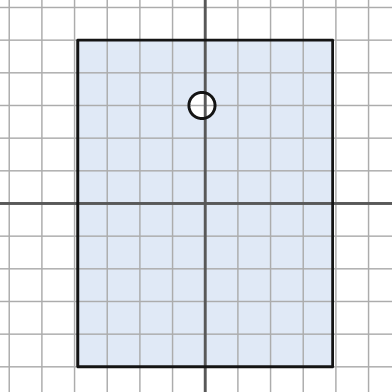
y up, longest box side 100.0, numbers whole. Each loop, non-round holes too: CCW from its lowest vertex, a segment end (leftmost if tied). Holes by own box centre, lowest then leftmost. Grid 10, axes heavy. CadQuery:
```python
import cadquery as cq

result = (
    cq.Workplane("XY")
    .moveTo(-39.0, -50.0)
    .lineTo(39.0, -50.0)
    .lineTo(39.0, 50.0)
    .lineTo(-39.0, 50.0)
    .close()
    .moveTo(-1.0, 30.0)
    .circle(4.0)
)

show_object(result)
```